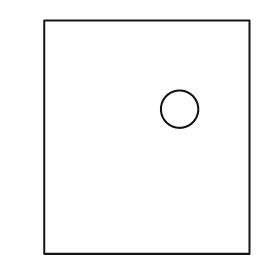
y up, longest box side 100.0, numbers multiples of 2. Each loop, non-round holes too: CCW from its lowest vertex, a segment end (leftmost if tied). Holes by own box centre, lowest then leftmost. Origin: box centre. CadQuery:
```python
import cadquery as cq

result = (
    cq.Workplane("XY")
    .moveTo(-44.0, -50.0)
    .lineTo(44.0, -50.0)
    .lineTo(44.0, 50.0)
    .lineTo(-44.0, 50.0)
    .close()
    .moveTo(14.0, 12.0)
    .circle(8.0)
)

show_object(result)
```